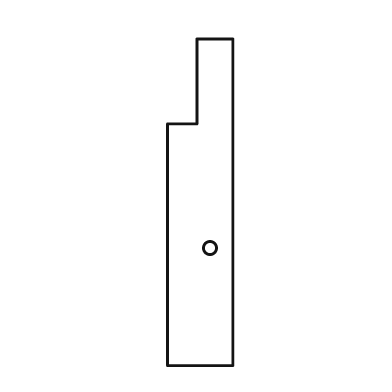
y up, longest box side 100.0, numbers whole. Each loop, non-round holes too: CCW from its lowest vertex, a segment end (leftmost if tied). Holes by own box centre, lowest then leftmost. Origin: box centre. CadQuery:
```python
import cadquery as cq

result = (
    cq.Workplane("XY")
    .moveTo(-10.0, -50.0)
    .lineTo(10.0, -50.0)
    .lineTo(10.0, 50.0)
    .lineTo(-1.0, 50.0)
    .lineTo(-1.0, 24.0)
    .lineTo(-10.0, 24.0)
    .close()
    .moveTo(3.0, -14.0)
    .circle(2.0)
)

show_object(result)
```